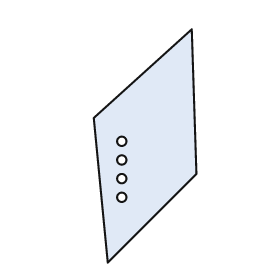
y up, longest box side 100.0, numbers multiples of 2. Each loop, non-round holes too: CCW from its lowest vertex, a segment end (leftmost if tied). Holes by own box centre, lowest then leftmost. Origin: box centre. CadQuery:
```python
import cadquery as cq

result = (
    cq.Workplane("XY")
    .moveTo(-16.0, -50.0)
    .lineTo(22.0, -12.0)
    .lineTo(20.0, 50.0)
    .lineTo(-22.0, 12.0)
    .close()
    .moveTo(-10.0, -22.0)
    .circle(2.0)
    .moveTo(-10.0, -14.0)
    .circle(2.0)
    .moveTo(-10.0, -6.0)
    .circle(2.0)
    .moveTo(-10.0, 2.0)
    .circle(2.0)
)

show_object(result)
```